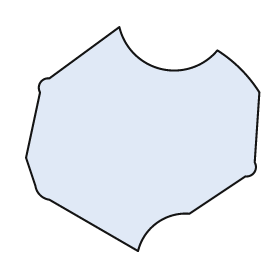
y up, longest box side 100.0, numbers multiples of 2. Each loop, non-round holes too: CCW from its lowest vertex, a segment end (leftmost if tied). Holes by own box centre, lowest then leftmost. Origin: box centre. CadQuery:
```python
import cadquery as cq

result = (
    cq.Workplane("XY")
    .moveTo(-2.0, -48.0)
    .threePointArc((6.0, -36.0), (20.0, -32.0))
    .lineTo(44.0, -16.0)
    .threePointArc((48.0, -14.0), (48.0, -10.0))
    .lineTo(50.0, 20.0)
    .threePointArc((42.0, 30.0), (32.0, 38.0))
    .threePointArc((8.0, 30.0), (-10.0, 48.0))
    .lineTo(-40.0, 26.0)
    .threePointArc((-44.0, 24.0), (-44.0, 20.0))
    .lineTo(-50.0, -8.0)
    .lineTo(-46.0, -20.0)
    .threePointArc((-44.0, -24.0), (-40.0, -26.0))
    .close()
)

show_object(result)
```